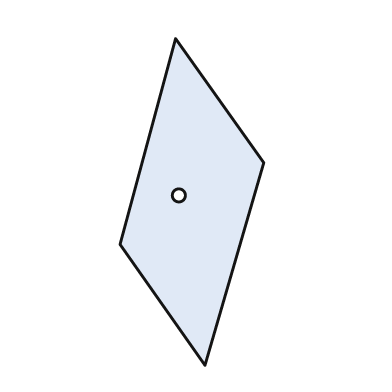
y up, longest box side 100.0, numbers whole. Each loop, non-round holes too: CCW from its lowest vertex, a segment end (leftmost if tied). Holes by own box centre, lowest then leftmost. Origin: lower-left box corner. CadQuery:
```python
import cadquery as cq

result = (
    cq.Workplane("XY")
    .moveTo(26.0, 0.0)
    .lineTo(44.0, 62.0)
    .lineTo(17.0, 100.0)
    .lineTo(0.0, 37.0)
    .close()
    .moveTo(18.0, 52.0)
    .circle(2.0)
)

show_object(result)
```